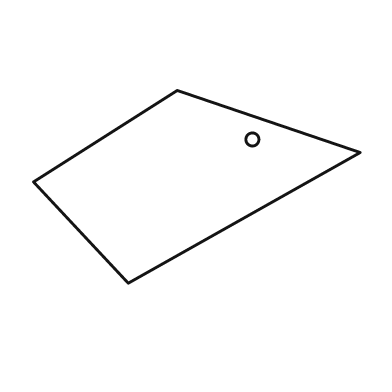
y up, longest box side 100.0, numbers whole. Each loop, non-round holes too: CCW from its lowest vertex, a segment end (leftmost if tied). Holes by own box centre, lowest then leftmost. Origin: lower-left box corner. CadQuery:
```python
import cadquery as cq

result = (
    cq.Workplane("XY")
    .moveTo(29.0, 0.0)
    .lineTo(100.0, 40.0)
    .lineTo(44.0, 59.0)
    .lineTo(0.0, 31.0)
    .close()
    .moveTo(67.0, 44.0)
    .circle(2.0)
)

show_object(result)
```